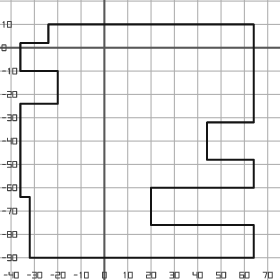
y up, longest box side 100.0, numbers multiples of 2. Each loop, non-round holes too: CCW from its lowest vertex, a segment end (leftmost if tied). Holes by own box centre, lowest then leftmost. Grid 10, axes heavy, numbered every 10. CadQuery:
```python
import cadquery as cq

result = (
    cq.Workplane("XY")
    .moveTo(-32.0, -90.0)
    .lineTo(64.0, -90.0)
    .lineTo(64.0, -76.0)
    .lineTo(20.0, -76.0)
    .lineTo(20.0, -60.0)
    .lineTo(64.0, -60.0)
    .lineTo(64.0, -48.0)
    .lineTo(44.0, -48.0)
    .lineTo(44.0, -32.0)
    .lineTo(64.0, -32.0)
    .lineTo(64.0, 10.0)
    .lineTo(-24.0, 10.0)
    .lineTo(-24.0, 2.0)
    .lineTo(-36.0, 2.0)
    .lineTo(-36.0, -10.0)
    .lineTo(-20.0, -10.0)
    .lineTo(-20.0, -24.0)
    .lineTo(-36.0, -24.0)
    .lineTo(-36.0, -64.0)
    .lineTo(-32.0, -64.0)
    .close()
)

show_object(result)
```